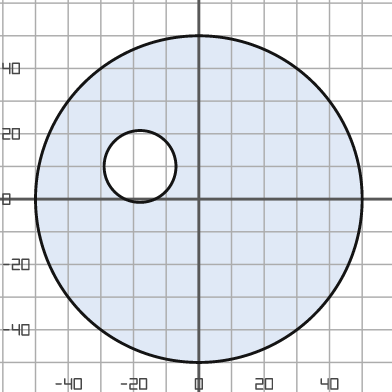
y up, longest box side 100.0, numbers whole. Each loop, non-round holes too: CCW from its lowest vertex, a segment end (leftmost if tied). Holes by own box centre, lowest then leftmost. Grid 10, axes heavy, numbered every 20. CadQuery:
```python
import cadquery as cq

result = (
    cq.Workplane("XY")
    .moveTo(0.0, 0.0)
    .circle(50.0)
    .moveTo(-18.0, 10.0)
    .circle(11.0)
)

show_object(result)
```